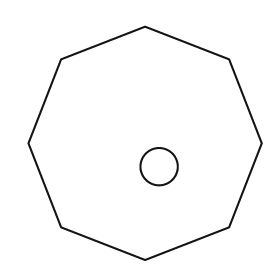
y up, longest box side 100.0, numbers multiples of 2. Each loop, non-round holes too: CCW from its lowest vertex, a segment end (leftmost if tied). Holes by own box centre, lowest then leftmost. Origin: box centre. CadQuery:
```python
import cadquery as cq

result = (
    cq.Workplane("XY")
    .moveTo(0.0, -50.0)
    .lineTo(36.0, -36.0)
    .lineTo(50.0, 0.0)
    .lineTo(36.0, 36.0)
    .lineTo(0.0, 50.0)
    .lineTo(-36.0, 36.0)
    .lineTo(-50.0, 0.0)
    .lineTo(-36.0, -36.0)
    .close()
    .moveTo(6.0, -10.0)
    .circle(8.0)
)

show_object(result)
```